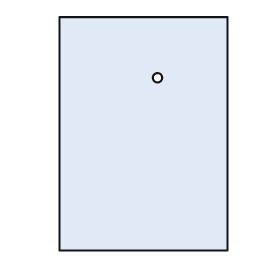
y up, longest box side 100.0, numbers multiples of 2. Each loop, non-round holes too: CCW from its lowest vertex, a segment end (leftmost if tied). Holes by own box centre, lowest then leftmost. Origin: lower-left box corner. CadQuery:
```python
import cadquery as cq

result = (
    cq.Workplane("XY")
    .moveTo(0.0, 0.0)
    .lineTo(72.0, 0.0)
    .lineTo(72.0, 100.0)
    .lineTo(0.0, 100.0)
    .close()
    .moveTo(42.0, 74.0)
    .circle(2.0)
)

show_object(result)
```